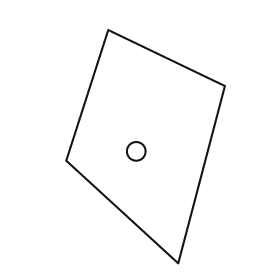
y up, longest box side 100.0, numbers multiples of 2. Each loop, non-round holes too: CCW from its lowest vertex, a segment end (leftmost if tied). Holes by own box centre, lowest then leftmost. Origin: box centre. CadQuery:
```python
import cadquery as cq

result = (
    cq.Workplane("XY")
    .moveTo(14.0, -50.0)
    .lineTo(34.0, 26.0)
    .lineTo(-16.0, 50.0)
    .lineTo(-34.0, -6.0)
    .close()
    .moveTo(-4.0, -2.0)
    .circle(4.0)
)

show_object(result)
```